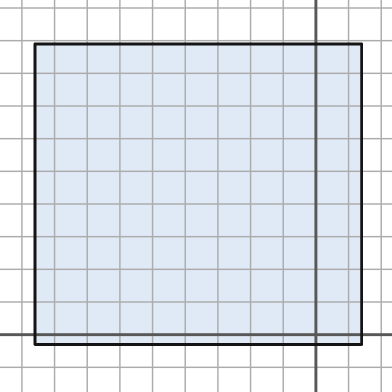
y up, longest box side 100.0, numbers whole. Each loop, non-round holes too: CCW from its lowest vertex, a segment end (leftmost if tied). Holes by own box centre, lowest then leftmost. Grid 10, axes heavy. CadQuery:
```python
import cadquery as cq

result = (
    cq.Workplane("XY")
    .moveTo(-86.0, -3.0)
    .lineTo(14.0, -3.0)
    .lineTo(14.0, 89.0)
    .lineTo(-86.0, 89.0)
    .close()
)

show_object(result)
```